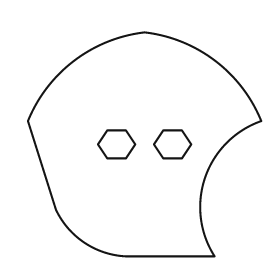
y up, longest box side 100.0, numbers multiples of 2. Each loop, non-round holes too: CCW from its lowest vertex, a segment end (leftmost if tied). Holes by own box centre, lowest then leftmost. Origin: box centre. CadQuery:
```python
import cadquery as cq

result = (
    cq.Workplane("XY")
    .moveTo(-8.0, -48.0)
    .lineTo(30.0, -48.0)
    .threePointArc((26.0, -14.0), (50.0, 10.0))
    .threePointArc((30.0, 36.0), (0.0, 48.0))
    .threePointArc((-30.0, 36.0), (-50.0, 10.0))
    .lineTo(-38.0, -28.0)
    .threePointArc((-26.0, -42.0), (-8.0, -48.0))
    .close()
    .moveTo(-16.0, -6.0)
    .lineTo(-8.0, -6.0)
    .lineTo(-4.0, 0.0)
    .lineTo(-8.0, 6.0)
    .lineTo(-16.0, 6.0)
    .lineTo(-20.0, 0.0)
    .close()
    .moveTo(8.0, -6.0)
    .lineTo(16.0, -6.0)
    .lineTo(20.0, 0.0)
    .lineTo(16.0, 6.0)
    .lineTo(8.0, 6.0)
    .lineTo(4.0, 0.0)
    .close()
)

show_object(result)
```